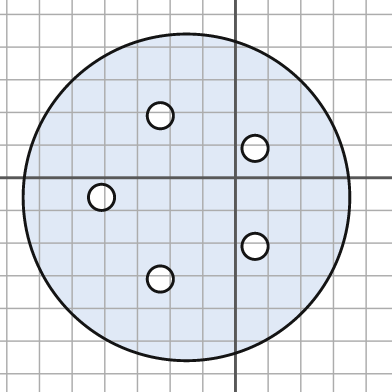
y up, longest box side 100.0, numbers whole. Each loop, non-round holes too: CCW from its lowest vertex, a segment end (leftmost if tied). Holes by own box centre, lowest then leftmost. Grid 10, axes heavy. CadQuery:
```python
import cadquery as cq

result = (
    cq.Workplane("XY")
    .moveTo(-15.0, -6.0)
    .circle(50.0)
    .moveTo(-23.0, -31.0)
    .circle(4.0)
    .moveTo(6.0, -21.0)
    .circle(4.0)
    .moveTo(-41.0, -6.0)
    .circle(4.0)
    .moveTo(6.0, 9.0)
    .circle(4.0)
    .moveTo(-23.0, 19.0)
    .circle(4.0)
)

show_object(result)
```